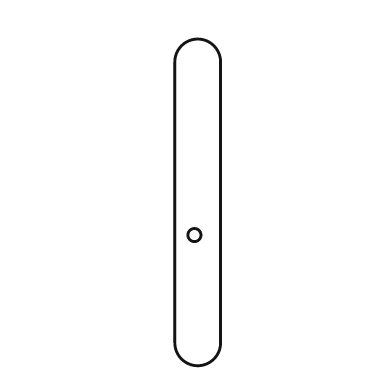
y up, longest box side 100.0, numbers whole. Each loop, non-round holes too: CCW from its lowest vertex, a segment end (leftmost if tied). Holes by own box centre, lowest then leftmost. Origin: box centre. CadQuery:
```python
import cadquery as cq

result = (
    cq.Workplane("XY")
    .moveTo(-7.0, -43.0)
    .threePointArc((0.0, -50.0), (7.0, -43.0))
    .lineTo(7.0, 43.0)
    .threePointArc((0.0, 50.0), (-7.0, 43.0))
    .close()
    .moveTo(-1.0, -10.0)
    .circle(2.0)
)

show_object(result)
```